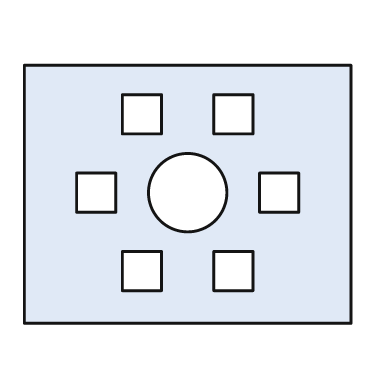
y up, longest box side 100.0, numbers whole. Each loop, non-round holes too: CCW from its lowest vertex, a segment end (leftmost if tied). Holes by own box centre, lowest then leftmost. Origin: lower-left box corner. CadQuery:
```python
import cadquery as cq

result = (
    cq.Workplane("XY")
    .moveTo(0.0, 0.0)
    .lineTo(100.0, 0.0)
    .lineTo(100.0, 79.0)
    .lineTo(0.0, 79.0)
    .close()
    .moveTo(30.0, 10.0)
    .lineTo(42.0, 10.0)
    .lineTo(42.0, 22.0)
    .lineTo(30.0, 22.0)
    .close()
    .moveTo(58.0, 10.0)
    .lineTo(70.0, 10.0)
    .lineTo(70.0, 22.0)
    .lineTo(58.0, 22.0)
    .close()
    .moveTo(16.0, 34.0)
    .lineTo(28.0, 34.0)
    .lineTo(28.0, 46.0)
    .lineTo(16.0, 46.0)
    .close()
    .moveTo(50.0, 40.0)
    .circle(12.0)
    .moveTo(72.0, 34.0)
    .lineTo(84.0, 34.0)
    .lineTo(84.0, 46.0)
    .lineTo(72.0, 46.0)
    .close()
    .moveTo(30.0, 58.0)
    .lineTo(42.0, 58.0)
    .lineTo(42.0, 70.0)
    .lineTo(30.0, 70.0)
    .close()
    .moveTo(58.0, 58.0)
    .lineTo(70.0, 58.0)
    .lineTo(70.0, 70.0)
    .lineTo(58.0, 70.0)
    .close()
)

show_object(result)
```